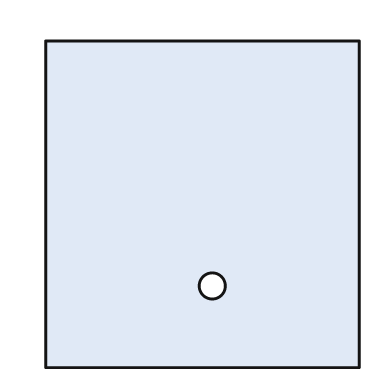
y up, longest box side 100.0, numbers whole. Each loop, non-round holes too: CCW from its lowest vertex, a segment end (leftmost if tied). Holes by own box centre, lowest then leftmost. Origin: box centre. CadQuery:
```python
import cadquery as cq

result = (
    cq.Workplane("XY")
    .moveTo(-48.0, -50.0)
    .lineTo(48.0, -50.0)
    .lineTo(48.0, 50.0)
    .lineTo(-48.0, 50.0)
    .close()
    .moveTo(3.0, -25.0)
    .circle(4.0)
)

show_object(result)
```